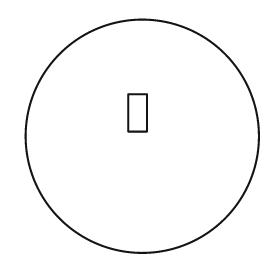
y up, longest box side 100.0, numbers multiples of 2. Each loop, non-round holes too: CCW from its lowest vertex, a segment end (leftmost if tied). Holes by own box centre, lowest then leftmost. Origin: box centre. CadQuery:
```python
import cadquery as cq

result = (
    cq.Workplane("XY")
    .moveTo(0.0, 0.0)
    .circle(50.0)
    .moveTo(-6.0, 2.0)
    .lineTo(2.0, 2.0)
    .lineTo(2.0, 18.0)
    .lineTo(-6.0, 18.0)
    .close()
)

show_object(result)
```